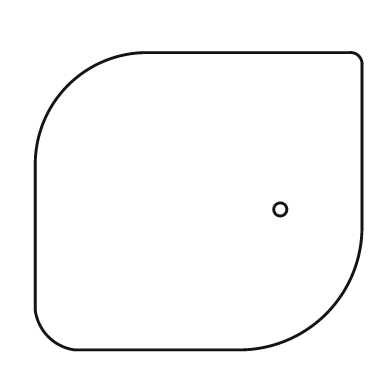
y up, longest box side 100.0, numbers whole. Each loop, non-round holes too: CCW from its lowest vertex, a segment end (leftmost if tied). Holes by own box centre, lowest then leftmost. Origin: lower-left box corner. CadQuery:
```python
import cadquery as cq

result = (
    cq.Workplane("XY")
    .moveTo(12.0, 0.0)
    .lineTo(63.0, 0.0)
    .threePointArc((89.0, 11.0), (100.0, 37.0))
    .lineTo(100.0, 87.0)
    .threePointArc((99.0, 90.0), (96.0, 91.0))
    .lineTo(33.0, 91.0)
    .threePointArc((10.0, 81.0), (0.0, 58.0))
    .lineTo(0.0, 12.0)
    .threePointArc((4.0, 4.0), (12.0, 0.0))
    .close()
    .moveTo(75.0, 43.0)
    .circle(2.0)
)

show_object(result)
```